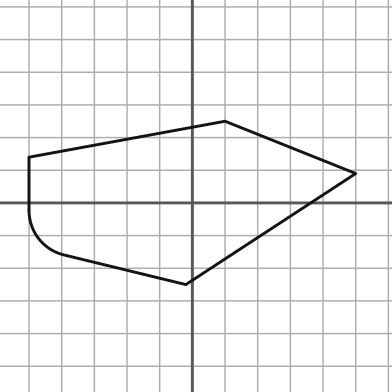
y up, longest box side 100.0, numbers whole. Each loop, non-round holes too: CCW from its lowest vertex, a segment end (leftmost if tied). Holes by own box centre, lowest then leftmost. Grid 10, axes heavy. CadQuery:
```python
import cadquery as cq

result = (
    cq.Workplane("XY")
    .moveTo(-2.0, -25.0)
    .lineTo(50.0, 9.0)
    .lineTo(10.0, 25.0)
    .lineTo(-50.0, 14.0)
    .lineTo(-50.0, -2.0)
    .threePointArc((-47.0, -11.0), (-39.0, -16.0))
    .close()
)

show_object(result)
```